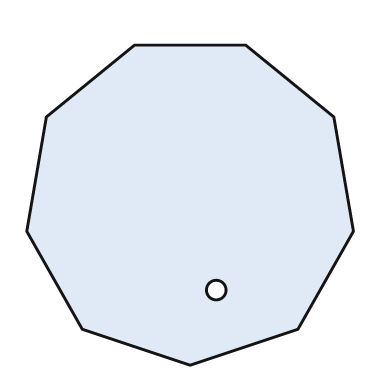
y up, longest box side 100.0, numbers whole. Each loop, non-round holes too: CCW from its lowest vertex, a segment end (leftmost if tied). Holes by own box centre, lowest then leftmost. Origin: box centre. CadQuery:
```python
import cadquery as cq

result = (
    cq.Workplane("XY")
    .moveTo(0.0, -49.0)
    .lineTo(33.0, -38.0)
    .lineTo(50.0, -8.0)
    .lineTo(44.0, 27.0)
    .lineTo(17.0, 49.0)
    .lineTo(-17.0, 49.0)
    .lineTo(-44.0, 27.0)
    .lineTo(-50.0, -8.0)
    .lineTo(-33.0, -38.0)
    .close()
    .moveTo(8.0, -26.0)
    .circle(3.0)
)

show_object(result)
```